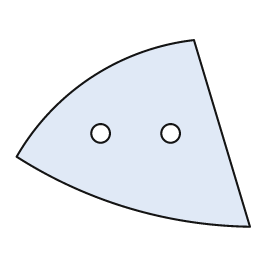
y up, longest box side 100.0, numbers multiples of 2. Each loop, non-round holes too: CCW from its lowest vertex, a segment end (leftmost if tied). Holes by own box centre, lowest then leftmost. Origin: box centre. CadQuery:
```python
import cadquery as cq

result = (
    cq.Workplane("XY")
    .moveTo(50.0, -40.0)
    .lineTo(26.0, 40.0)
    .threePointArc((-18.0, 24.0), (-50.0, -10.0))
    .threePointArc((-2.0, -32.0), (50.0, -40.0))
    .close()
    .moveTo(-14.0, 0.0)
    .circle(4.0)
    .moveTo(16.0, 0.0)
    .circle(4.0)
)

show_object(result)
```